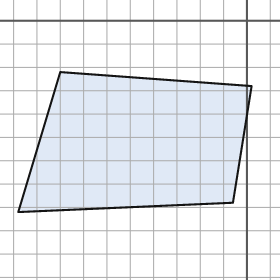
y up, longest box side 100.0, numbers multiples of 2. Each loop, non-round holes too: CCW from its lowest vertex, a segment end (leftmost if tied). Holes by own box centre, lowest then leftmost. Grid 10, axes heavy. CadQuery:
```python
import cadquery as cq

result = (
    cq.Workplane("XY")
    .moveTo(-98.0, -82.0)
    .lineTo(-6.0, -78.0)
    .lineTo(2.0, -28.0)
    .lineTo(-80.0, -22.0)
    .close()
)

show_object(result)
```